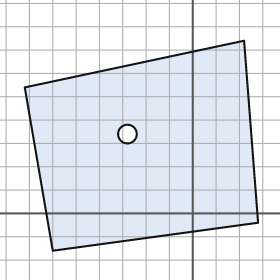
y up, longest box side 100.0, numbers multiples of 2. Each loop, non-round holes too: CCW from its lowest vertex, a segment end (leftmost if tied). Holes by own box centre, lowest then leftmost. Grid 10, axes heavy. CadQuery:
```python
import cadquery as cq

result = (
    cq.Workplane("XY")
    .moveTo(-60.0, -16.0)
    .lineTo(28.0, -4.0)
    .lineTo(22.0, 74.0)
    .lineTo(-72.0, 54.0)
    .close()
    .moveTo(-28.0, 34.0)
    .circle(4.0)
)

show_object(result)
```